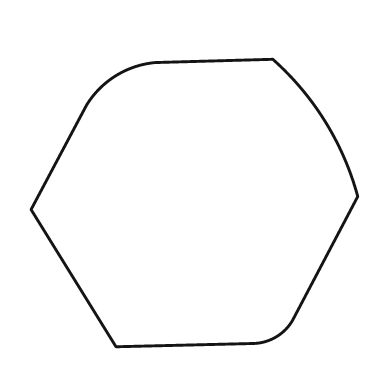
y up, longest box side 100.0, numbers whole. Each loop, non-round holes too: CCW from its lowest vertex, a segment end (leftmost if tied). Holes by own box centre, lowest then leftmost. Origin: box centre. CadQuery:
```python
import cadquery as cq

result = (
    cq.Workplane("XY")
    .moveTo(-24.0, -44.0)
    .lineTo(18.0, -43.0)
    .threePointArc((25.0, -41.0), (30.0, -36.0))
    .lineTo(50.0, 2.0)
    .threePointArc((40.0, 25.0), (24.0, 44.0))
    .lineTo(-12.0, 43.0)
    .threePointArc((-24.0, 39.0), (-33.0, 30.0))
    .lineTo(-50.0, -2.0)
    .close()
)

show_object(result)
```